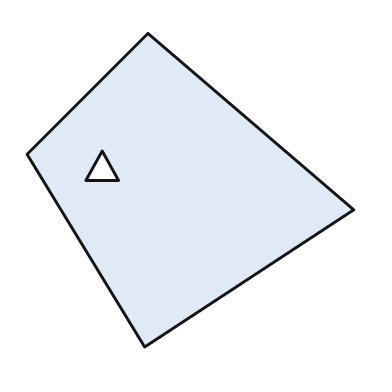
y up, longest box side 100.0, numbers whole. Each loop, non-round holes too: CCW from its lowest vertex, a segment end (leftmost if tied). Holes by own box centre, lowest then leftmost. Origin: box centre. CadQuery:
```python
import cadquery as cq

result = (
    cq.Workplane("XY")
    .moveTo(-14.0, -48.0)
    .lineTo(50.0, -6.0)
    .lineTo(-13.0, 48.0)
    .lineTo(-50.0, 11.0)
    .close()
    .moveTo(-32.0, 3.0)
    .lineTo(-22.0, 3.0)
    .lineTo(-27.0, 12.0)
    .close()
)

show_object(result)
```